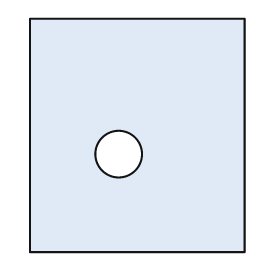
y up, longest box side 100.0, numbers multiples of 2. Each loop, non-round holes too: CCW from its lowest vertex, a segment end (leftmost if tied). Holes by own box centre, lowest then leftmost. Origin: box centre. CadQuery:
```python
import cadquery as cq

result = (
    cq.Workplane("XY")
    .moveTo(-46.0, -50.0)
    .lineTo(46.0, -50.0)
    .lineTo(46.0, 50.0)
    .lineTo(-46.0, 50.0)
    .close()
    .moveTo(-8.0, -8.0)
    .circle(10.0)
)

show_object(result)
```